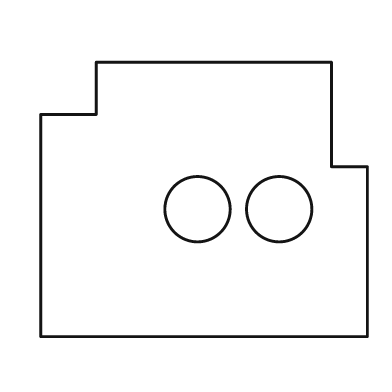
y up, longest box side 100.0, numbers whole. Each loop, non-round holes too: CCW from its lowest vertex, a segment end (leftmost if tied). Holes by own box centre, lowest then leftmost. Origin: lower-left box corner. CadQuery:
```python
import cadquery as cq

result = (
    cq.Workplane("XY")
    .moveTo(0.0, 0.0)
    .lineTo(100.0, 0.0)
    .lineTo(100.0, 52.0)
    .lineTo(89.0, 52.0)
    .lineTo(89.0, 84.0)
    .lineTo(17.0, 84.0)
    .lineTo(17.0, 68.0)
    .lineTo(0.0, 68.0)
    .close()
    .moveTo(48.0, 39.0)
    .circle(10.0)
    .moveTo(73.0, 39.0)
    .circle(10.0)
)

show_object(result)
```